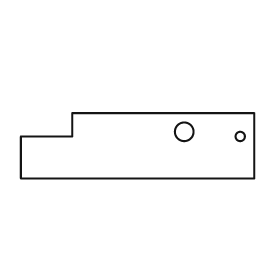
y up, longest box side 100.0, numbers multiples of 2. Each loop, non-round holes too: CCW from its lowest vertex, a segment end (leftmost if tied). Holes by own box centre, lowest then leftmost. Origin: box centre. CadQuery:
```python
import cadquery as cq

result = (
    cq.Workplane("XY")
    .moveTo(-50.0, -14.0)
    .lineTo(50.0, -14.0)
    .lineTo(50.0, 14.0)
    .lineTo(-28.0, 14.0)
    .lineTo(-28.0, 4.0)
    .lineTo(-50.0, 4.0)
    .close()
    .moveTo(44.0, 4.0)
    .circle(2.0)
    .moveTo(20.0, 6.0)
    .circle(4.0)
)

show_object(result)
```